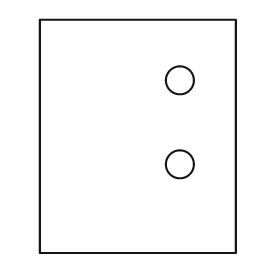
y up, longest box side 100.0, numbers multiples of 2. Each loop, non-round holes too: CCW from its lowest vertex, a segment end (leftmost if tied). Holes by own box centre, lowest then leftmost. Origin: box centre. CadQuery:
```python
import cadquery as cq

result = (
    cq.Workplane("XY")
    .moveTo(-42.0, -50.0)
    .lineTo(42.0, -50.0)
    .lineTo(42.0, 50.0)
    .lineTo(-42.0, 50.0)
    .close()
    .moveTo(18.0, -12.0)
    .circle(6.0)
    .moveTo(18.0, 24.0)
    .circle(6.0)
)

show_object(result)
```